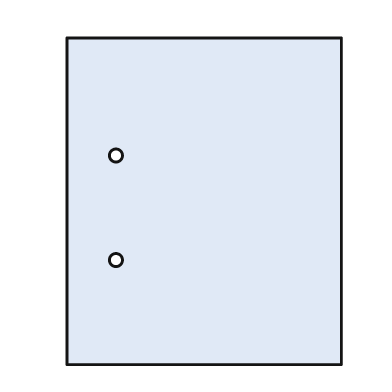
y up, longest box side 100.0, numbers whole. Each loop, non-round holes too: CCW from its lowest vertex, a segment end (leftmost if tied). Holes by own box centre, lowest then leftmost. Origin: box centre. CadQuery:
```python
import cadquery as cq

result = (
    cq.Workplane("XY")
    .moveTo(-42.0, -50.0)
    .lineTo(42.0, -50.0)
    .lineTo(42.0, 50.0)
    .lineTo(-42.0, 50.0)
    .close()
    .moveTo(-27.0, -18.0)
    .circle(2.0)
    .moveTo(-27.0, 14.0)
    .circle(2.0)
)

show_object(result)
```